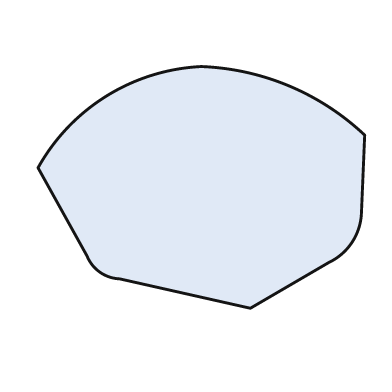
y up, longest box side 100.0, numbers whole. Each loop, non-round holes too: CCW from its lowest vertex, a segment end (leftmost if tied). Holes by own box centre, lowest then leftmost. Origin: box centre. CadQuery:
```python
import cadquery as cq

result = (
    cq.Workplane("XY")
    .moveTo(15.0, -37.0)
    .lineTo(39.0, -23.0)
    .threePointArc((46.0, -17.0), (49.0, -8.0))
    .lineTo(50.0, 16.0)
    .threePointArc((27.0, 31.0), (0.0, 37.0))
    .threePointArc((-29.0, 28.0), (-50.0, 6.0))
    .lineTo(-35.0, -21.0)
    .threePointArc((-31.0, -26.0), (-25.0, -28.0))
    .close()
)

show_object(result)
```